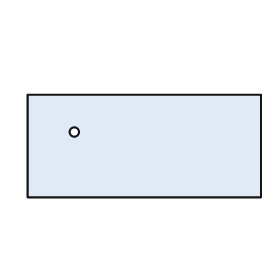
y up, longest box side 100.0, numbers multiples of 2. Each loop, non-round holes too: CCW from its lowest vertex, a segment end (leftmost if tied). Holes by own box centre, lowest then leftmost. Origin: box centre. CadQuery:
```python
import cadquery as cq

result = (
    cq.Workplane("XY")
    .moveTo(-50.0, -22.0)
    .lineTo(50.0, -22.0)
    .lineTo(50.0, 22.0)
    .lineTo(-50.0, 22.0)
    .close()
    .moveTo(-30.0, 6.0)
    .circle(2.0)
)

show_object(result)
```